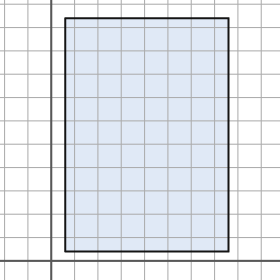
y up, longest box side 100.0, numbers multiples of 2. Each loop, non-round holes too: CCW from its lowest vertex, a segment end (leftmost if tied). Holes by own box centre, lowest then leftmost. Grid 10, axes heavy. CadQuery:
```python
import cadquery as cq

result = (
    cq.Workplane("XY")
    .moveTo(6.0, 4.0)
    .lineTo(76.0, 4.0)
    .lineTo(76.0, 104.0)
    .lineTo(6.0, 104.0)
    .close()
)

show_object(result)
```